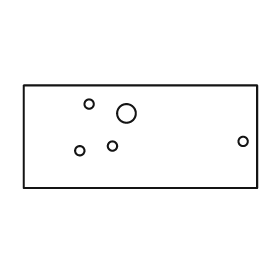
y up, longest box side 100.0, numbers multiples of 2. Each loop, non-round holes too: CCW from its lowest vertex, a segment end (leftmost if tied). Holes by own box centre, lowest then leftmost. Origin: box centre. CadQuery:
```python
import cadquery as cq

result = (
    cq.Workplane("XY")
    .moveTo(-50.0, -22.0)
    .lineTo(50.0, -22.0)
    .lineTo(50.0, 22.0)
    .lineTo(-50.0, 22.0)
    .close()
    .moveTo(-26.0, -6.0)
    .circle(2.0)
    .moveTo(-12.0, -4.0)
    .circle(2.0)
    .moveTo(44.0, -2.0)
    .circle(2.0)
    .moveTo(-6.0, 10.0)
    .circle(4.0)
    .moveTo(-22.0, 14.0)
    .circle(2.0)
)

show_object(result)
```